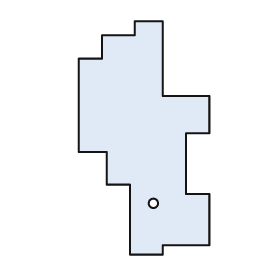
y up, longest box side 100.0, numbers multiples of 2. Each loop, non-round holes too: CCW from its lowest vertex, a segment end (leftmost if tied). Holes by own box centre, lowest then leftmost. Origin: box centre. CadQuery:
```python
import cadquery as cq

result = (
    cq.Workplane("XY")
    .moveTo(-6.0, -50.0)
    .lineTo(8.0, -50.0)
    .lineTo(8.0, -46.0)
    .lineTo(28.0, -46.0)
    .lineTo(28.0, -24.0)
    .lineTo(18.0, -24.0)
    .lineTo(18.0, 2.0)
    .lineTo(28.0, 2.0)
    .lineTo(28.0, 18.0)
    .lineTo(8.0, 18.0)
    .lineTo(8.0, 50.0)
    .lineTo(-4.0, 50.0)
    .lineTo(-4.0, 44.0)
    .lineTo(-18.0, 44.0)
    .lineTo(-18.0, 34.0)
    .lineTo(-28.0, 34.0)
    .lineTo(-28.0, -6.0)
    .lineTo(-16.0, -6.0)
    .lineTo(-16.0, -20.0)
    .lineTo(-6.0, -20.0)
    .close()
    .moveTo(4.0, -28.0)
    .circle(2.0)
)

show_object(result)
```